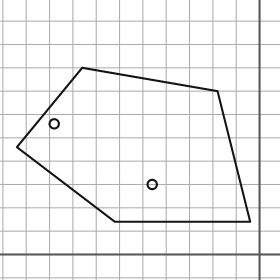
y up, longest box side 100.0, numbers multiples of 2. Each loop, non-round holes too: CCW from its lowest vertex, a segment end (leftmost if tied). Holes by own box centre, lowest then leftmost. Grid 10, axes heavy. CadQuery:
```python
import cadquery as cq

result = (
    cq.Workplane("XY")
    .moveTo(-62.0, 14.0)
    .lineTo(-4.0, 14.0)
    .lineTo(-18.0, 70.0)
    .lineTo(-76.0, 80.0)
    .lineTo(-104.0, 46.0)
    .close()
    .moveTo(-46.0, 30.0)
    .circle(2.0)
    .moveTo(-88.0, 56.0)
    .circle(2.0)
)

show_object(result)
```